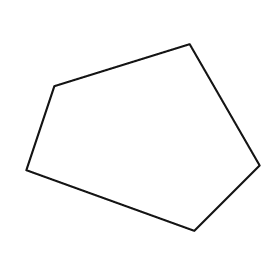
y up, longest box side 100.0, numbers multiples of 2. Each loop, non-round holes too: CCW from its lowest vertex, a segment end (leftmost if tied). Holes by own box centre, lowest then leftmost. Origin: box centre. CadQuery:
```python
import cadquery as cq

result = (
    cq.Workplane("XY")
    .moveTo(22.0, -40.0)
    .lineTo(50.0, -12.0)
    .lineTo(20.0, 40.0)
    .lineTo(-38.0, 22.0)
    .lineTo(-50.0, -14.0)
    .close()
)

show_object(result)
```